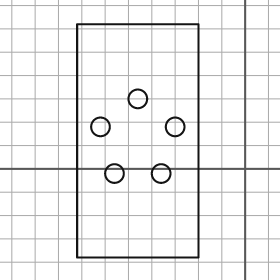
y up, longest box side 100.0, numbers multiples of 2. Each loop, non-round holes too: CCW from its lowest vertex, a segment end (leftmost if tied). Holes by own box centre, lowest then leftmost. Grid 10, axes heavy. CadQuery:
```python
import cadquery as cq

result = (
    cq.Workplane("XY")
    .moveTo(-72.0, -38.0)
    .lineTo(-20.0, -38.0)
    .lineTo(-20.0, 62.0)
    .lineTo(-72.0, 62.0)
    .close()
    .moveTo(-56.0, -2.0)
    .circle(4.0)
    .moveTo(-36.0, -2.0)
    .circle(4.0)
    .moveTo(-62.0, 18.0)
    .circle(4.0)
    .moveTo(-30.0, 18.0)
    .circle(4.0)
    .moveTo(-46.0, 30.0)
    .circle(4.0)
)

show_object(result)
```